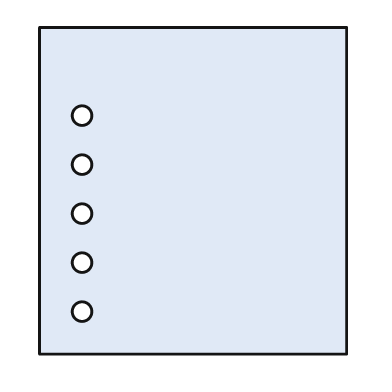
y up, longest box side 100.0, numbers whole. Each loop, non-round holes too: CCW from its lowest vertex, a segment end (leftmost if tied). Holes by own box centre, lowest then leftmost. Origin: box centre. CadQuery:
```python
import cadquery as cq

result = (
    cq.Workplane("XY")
    .moveTo(-47.0, -50.0)
    .lineTo(47.0, -50.0)
    .lineTo(47.0, 50.0)
    .lineTo(-47.0, 50.0)
    .close()
    .moveTo(-34.0, -37.0)
    .circle(3.0)
    .moveTo(-34.0, -22.0)
    .circle(3.0)
    .moveTo(-34.0, -7.0)
    .circle(3.0)
    .moveTo(-34.0, 8.0)
    .circle(3.0)
    .moveTo(-34.0, 23.0)
    .circle(3.0)
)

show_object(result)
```